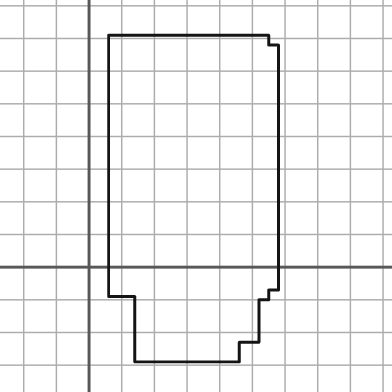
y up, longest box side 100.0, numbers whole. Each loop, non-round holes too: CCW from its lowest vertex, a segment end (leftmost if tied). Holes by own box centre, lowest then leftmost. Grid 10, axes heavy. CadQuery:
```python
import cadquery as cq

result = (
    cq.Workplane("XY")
    .moveTo(14.0, -29.0)
    .lineTo(46.0, -29.0)
    .lineTo(46.0, -23.0)
    .lineTo(52.0, -23.0)
    .lineTo(52.0, -10.0)
    .lineTo(55.0, -10.0)
    .lineTo(55.0, -7.0)
    .lineTo(58.0, -7.0)
    .lineTo(58.0, 68.0)
    .lineTo(55.0, 68.0)
    .lineTo(55.0, 71.0)
    .lineTo(6.0, 71.0)
    .lineTo(6.0, -9.0)
    .lineTo(14.0, -9.0)
    .close()
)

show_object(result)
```